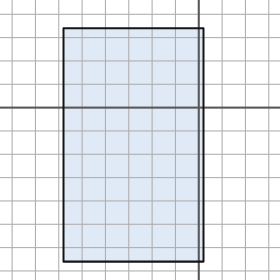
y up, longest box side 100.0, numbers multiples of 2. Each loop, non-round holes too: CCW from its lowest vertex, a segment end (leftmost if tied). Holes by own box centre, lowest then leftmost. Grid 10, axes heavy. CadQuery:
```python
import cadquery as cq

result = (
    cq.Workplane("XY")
    .moveTo(-58.0, -66.0)
    .lineTo(2.0, -66.0)
    .lineTo(2.0, 34.0)
    .lineTo(-58.0, 34.0)
    .close()
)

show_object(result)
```